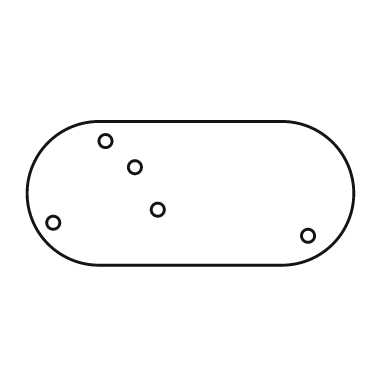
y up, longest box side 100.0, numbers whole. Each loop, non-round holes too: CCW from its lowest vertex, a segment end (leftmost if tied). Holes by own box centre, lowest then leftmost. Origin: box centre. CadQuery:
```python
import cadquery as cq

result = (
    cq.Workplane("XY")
    .moveTo(-28.0, -22.0)
    .lineTo(28.0, -22.0)
    .threePointArc((50.0, 0.0), (28.0, 22.0))
    .lineTo(-28.0, 22.0)
    .threePointArc((-50.0, 0.0), (-28.0, -22.0))
    .close()
    .moveTo(36.0, -13.0)
    .circle(2.0)
    .moveTo(-42.0, -9.0)
    .circle(2.0)
    .moveTo(-10.0, -5.0)
    .circle(2.0)
    .moveTo(-17.0, 8.0)
    .circle(2.0)
    .moveTo(-26.0, 16.0)
    .circle(2.0)
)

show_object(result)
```